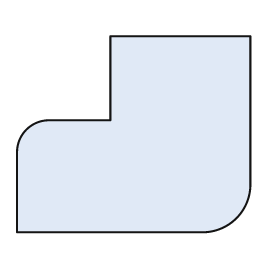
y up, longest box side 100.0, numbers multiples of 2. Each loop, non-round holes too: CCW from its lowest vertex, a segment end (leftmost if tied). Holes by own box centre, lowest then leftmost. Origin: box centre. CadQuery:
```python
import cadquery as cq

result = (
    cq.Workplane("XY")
    .moveTo(-50.0, -42.0)
    .lineTo(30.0, -42.0)
    .threePointArc((44.0, -36.0), (50.0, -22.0))
    .lineTo(50.0, 42.0)
    .lineTo(-10.0, 42.0)
    .lineTo(-10.0, 6.0)
    .lineTo(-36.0, 6.0)
    .threePointArc((-46.0, 2.0), (-50.0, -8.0))
    .close()
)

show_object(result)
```